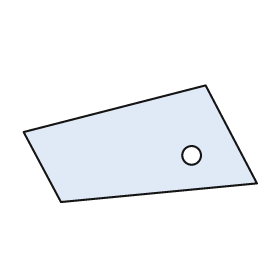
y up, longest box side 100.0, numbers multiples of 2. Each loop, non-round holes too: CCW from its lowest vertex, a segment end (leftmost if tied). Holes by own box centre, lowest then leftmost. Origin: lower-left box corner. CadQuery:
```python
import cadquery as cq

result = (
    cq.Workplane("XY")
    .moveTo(16.0, 0.0)
    .lineTo(100.0, 8.0)
    .lineTo(78.0, 50.0)
    .lineTo(0.0, 30.0)
    .close()
    .moveTo(72.0, 20.0)
    .circle(4.0)
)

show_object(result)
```